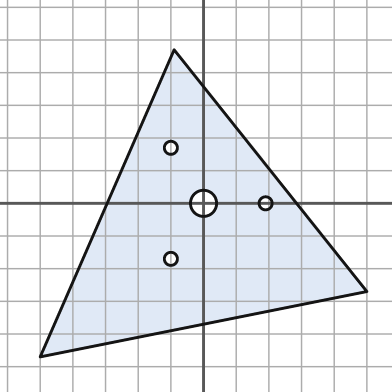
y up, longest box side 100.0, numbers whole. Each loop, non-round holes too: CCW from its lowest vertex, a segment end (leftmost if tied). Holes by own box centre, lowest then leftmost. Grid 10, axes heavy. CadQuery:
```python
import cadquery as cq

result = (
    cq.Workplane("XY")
    .moveTo(-50.0, -47.0)
    .lineTo(50.0, -27.0)
    .lineTo(-9.0, 47.0)
    .close()
    .moveTo(-10.0, -17.0)
    .circle(2.0)
    .moveTo(0.0, 0.0)
    .circle(4.0)
    .moveTo(19.0, 0.0)
    .circle(2.0)
    .moveTo(-10.0, 17.0)
    .circle(2.0)
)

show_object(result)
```